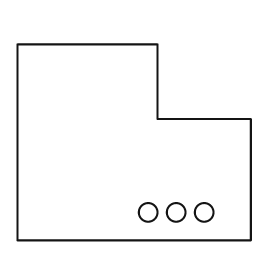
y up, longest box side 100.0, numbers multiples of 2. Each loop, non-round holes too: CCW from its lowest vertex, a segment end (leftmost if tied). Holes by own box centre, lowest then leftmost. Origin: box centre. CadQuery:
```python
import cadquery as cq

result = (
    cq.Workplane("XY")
    .moveTo(-50.0, -42.0)
    .lineTo(50.0, -42.0)
    .lineTo(50.0, 10.0)
    .lineTo(10.0, 10.0)
    .lineTo(10.0, 42.0)
    .lineTo(-50.0, 42.0)
    .close()
    .moveTo(6.0, -30.0)
    .circle(4.0)
    .moveTo(18.0, -30.0)
    .circle(4.0)
    .moveTo(30.0, -30.0)
    .circle(4.0)
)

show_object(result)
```